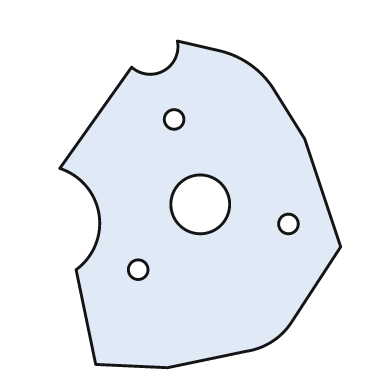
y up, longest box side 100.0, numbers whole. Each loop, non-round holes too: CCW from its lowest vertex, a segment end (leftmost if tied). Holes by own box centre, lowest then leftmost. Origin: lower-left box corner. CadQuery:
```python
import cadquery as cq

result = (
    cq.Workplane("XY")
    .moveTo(33.0, 0.0)
    .lineTo(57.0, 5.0)
    .threePointArc((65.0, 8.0), (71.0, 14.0))
    .lineTo(86.0, 37.0)
    .lineTo(75.0, 70.0)
    .lineTo(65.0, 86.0)
    .threePointArc((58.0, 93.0), (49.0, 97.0))
    .lineTo(36.0, 100.0)
    .threePointArc((32.0, 91.0), (22.0, 92.0))
    .lineTo(0.0, 61.0)
    .threePointArc((12.0, 47.0), (5.0, 30.0))
    .lineTo(11.0, 1.0)
    .close()
    .moveTo(24.0, 30.0)
    .circle(3.0)
    .moveTo(70.0, 44.0)
    .circle(3.0)
    .moveTo(43.0, 50.0)
    .circle(9.0)
    .moveTo(35.0, 76.0)
    .circle(3.0)
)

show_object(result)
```